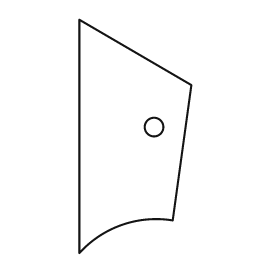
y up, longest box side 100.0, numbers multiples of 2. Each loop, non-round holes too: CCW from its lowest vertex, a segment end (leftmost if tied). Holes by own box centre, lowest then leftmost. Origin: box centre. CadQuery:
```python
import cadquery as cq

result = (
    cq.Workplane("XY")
    .moveTo(-24.0, -50.0)
    .threePointArc((-6.0, -38.0), (16.0, -36.0))
    .lineTo(24.0, 22.0)
    .lineTo(-24.0, 50.0)
    .close()
    .moveTo(8.0, 4.0)
    .circle(4.0)
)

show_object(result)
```